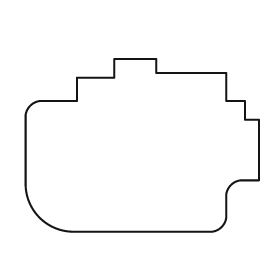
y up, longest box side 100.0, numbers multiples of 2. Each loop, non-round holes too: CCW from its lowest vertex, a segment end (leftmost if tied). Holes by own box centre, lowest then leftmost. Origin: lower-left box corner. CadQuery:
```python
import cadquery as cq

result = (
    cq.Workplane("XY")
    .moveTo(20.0, 0.0)
    .lineTo(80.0, 0.0)
    .threePointArc((84.0, 2.0), (86.0, 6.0))
    .lineTo(86.0, 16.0)
    .threePointArc((88.0, 20.0), (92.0, 22.0))
    .lineTo(100.0, 22.0)
    .lineTo(100.0, 48.0)
    .lineTo(94.0, 48.0)
    .lineTo(94.0, 56.0)
    .lineTo(86.0, 56.0)
    .lineTo(86.0, 68.0)
    .lineTo(56.0, 68.0)
    .lineTo(56.0, 74.0)
    .lineTo(38.0, 74.0)
    .lineTo(38.0, 66.0)
    .lineTo(22.0, 66.0)
    .lineTo(22.0, 56.0)
    .lineTo(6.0, 56.0)
    .threePointArc((2.0, 54.0), (0.0, 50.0))
    .lineTo(0.0, 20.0)
    .threePointArc((6.0, 6.0), (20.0, 0.0))
    .close()
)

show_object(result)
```